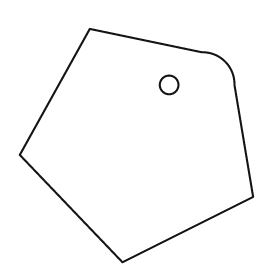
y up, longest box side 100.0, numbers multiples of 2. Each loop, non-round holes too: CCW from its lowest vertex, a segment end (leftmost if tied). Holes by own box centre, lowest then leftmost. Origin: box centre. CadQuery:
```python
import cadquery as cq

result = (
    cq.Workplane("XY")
    .moveTo(-6.0, -50.0)
    .lineTo(50.0, -22.0)
    .lineTo(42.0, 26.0)
    .threePointArc((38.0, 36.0), (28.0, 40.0))
    .lineTo(-20.0, 50.0)
    .lineTo(-50.0, -4.0)
    .close()
    .moveTo(14.0, 26.0)
    .circle(4.0)
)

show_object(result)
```